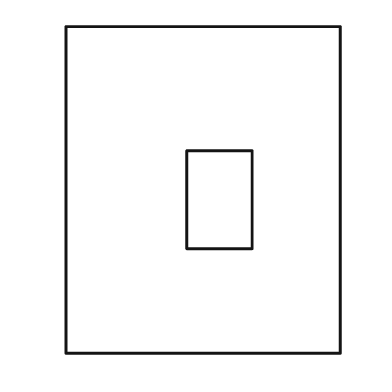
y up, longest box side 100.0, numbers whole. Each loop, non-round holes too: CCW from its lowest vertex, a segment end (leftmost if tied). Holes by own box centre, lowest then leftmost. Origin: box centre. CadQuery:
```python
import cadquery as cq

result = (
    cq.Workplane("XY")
    .moveTo(-42.0, -50.0)
    .lineTo(42.0, -50.0)
    .lineTo(42.0, 50.0)
    .lineTo(-42.0, 50.0)
    .close()
    .moveTo(-5.0, -18.0)
    .lineTo(15.0, -18.0)
    .lineTo(15.0, 12.0)
    .lineTo(-5.0, 12.0)
    .close()
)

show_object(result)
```